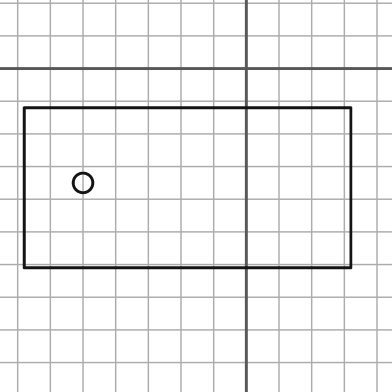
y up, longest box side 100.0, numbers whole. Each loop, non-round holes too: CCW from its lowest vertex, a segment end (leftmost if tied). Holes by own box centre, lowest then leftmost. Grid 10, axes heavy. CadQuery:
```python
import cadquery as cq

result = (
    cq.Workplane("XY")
    .moveTo(-68.0, -61.0)
    .lineTo(32.0, -61.0)
    .lineTo(32.0, -12.0)
    .lineTo(-68.0, -12.0)
    .close()
    .moveTo(-50.0, -35.0)
    .circle(3.0)
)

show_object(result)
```